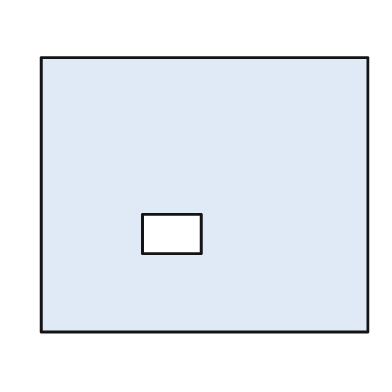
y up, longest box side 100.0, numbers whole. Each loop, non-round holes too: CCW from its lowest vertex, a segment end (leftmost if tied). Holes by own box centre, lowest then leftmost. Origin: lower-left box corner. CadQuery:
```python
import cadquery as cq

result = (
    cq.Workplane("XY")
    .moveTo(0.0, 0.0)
    .lineTo(100.0, 0.0)
    .lineTo(100.0, 84.0)
    .lineTo(0.0, 84.0)
    .close()
    .moveTo(31.0, 24.0)
    .lineTo(49.0, 24.0)
    .lineTo(49.0, 36.0)
    .lineTo(31.0, 36.0)
    .close()
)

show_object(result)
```